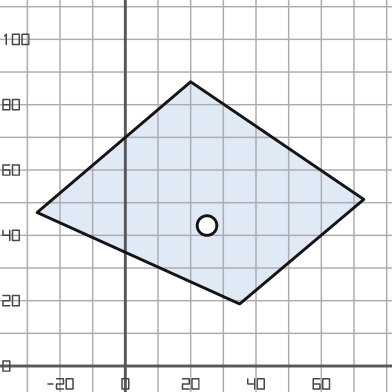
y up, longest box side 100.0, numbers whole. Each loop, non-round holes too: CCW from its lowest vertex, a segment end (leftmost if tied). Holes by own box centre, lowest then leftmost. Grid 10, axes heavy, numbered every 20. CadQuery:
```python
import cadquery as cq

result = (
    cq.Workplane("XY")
    .moveTo(35.0, 19.0)
    .lineTo(73.0, 51.0)
    .lineTo(20.0, 87.0)
    .lineTo(-27.0, 47.0)
    .close()
    .moveTo(25.0, 43.0)
    .circle(3.0)
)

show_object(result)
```